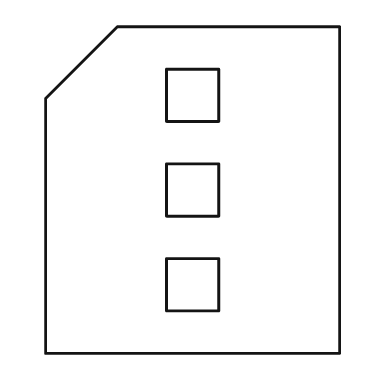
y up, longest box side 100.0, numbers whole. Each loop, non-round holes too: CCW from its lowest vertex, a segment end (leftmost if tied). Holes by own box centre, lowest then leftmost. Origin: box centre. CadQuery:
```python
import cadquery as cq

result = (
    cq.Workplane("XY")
    .moveTo(-45.0, -50.0)
    .lineTo(45.0, -50.0)
    .lineTo(45.0, 50.0)
    .lineTo(-23.0, 50.0)
    .lineTo(-45.0, 28.0)
    .close()
    .moveTo(-8.0, -37.0)
    .lineTo(8.0, -37.0)
    .lineTo(8.0, -21.0)
    .lineTo(-8.0, -21.0)
    .close()
    .moveTo(-8.0, -8.0)
    .lineTo(8.0, -8.0)
    .lineTo(8.0, 8.0)
    .lineTo(-8.0, 8.0)
    .close()
    .moveTo(-8.0, 21.0)
    .lineTo(8.0, 21.0)
    .lineTo(8.0, 37.0)
    .lineTo(-8.0, 37.0)
    .close()
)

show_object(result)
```